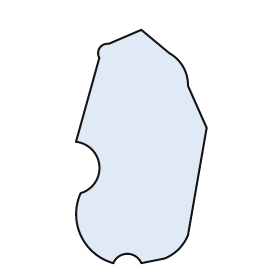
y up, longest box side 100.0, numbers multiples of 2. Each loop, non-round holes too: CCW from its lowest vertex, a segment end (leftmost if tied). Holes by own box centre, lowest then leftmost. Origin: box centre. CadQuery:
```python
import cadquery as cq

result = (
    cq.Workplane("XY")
    .moveTo(-12.0, -50.0)
    .threePointArc((-6.0, -46.0), (0.0, -50.0))
    .lineTo(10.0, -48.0)
    .threePointArc((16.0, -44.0), (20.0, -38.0))
    .lineTo(28.0, 8.0)
    .lineTo(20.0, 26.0)
    .threePointArc((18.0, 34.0), (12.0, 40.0))
    .lineTo(0.0, 50.0)
    .lineTo(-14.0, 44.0)
    .threePointArc((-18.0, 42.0), (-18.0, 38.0))
    .lineTo(-28.0, 2.0)
    .threePointArc((-18.0, -8.0), (-26.0, -20.0))
    .threePointArc((-26.0, -38.0), (-12.0, -50.0))
    .close()
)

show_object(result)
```